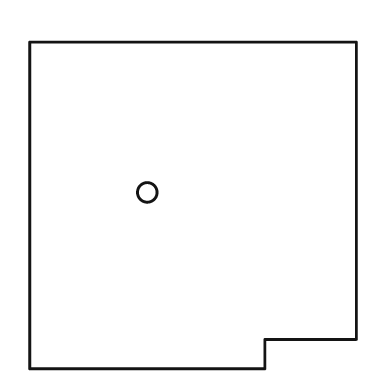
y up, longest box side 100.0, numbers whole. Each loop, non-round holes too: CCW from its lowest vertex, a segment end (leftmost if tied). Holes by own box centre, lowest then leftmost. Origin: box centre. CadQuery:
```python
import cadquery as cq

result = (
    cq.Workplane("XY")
    .moveTo(-50.0, -50.0)
    .lineTo(22.0, -50.0)
    .lineTo(22.0, -41.0)
    .lineTo(50.0, -41.0)
    .lineTo(50.0, 50.0)
    .lineTo(-50.0, 50.0)
    .close()
    .moveTo(-14.0, 4.0)
    .circle(3.0)
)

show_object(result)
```